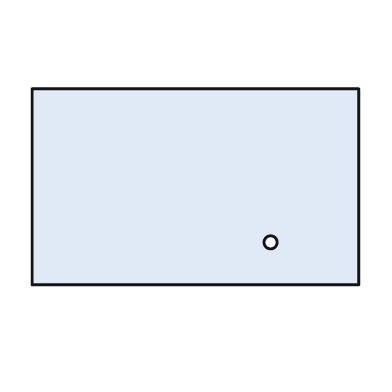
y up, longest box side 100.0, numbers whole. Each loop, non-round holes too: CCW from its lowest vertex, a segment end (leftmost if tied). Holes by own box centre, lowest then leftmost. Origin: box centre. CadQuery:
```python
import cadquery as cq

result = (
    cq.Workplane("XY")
    .moveTo(-50.0, -30.0)
    .lineTo(50.0, -30.0)
    .lineTo(50.0, 30.0)
    .lineTo(-50.0, 30.0)
    .close()
    .moveTo(23.0, -17.0)
    .circle(2.0)
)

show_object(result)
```